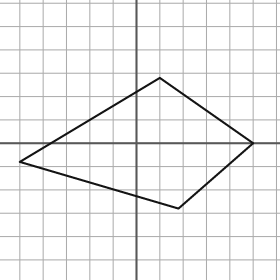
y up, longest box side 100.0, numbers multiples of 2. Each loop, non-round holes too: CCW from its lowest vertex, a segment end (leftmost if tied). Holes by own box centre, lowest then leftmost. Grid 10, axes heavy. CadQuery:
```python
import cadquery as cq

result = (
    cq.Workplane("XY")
    .moveTo(18.0, -28.0)
    .lineTo(50.0, 0.0)
    .lineTo(10.0, 28.0)
    .lineTo(-50.0, -8.0)
    .close()
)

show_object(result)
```